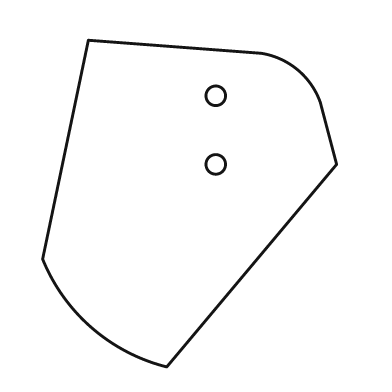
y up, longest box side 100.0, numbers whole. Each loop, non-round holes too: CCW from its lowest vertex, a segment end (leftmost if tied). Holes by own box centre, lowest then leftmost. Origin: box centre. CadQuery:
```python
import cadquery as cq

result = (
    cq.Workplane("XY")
    .moveTo(-7.0, -50.0)
    .lineTo(45.0, 12.0)
    .lineTo(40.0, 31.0)
    .threePointArc((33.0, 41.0), (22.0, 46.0))
    .lineTo(-31.0, 50.0)
    .lineTo(-45.0, -17.0)
    .threePointArc((-30.0, -38.0), (-7.0, -50.0))
    .close()
    .moveTo(8.0, 12.0)
    .circle(3.0)
    .moveTo(8.0, 33.0)
    .circle(3.0)
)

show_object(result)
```